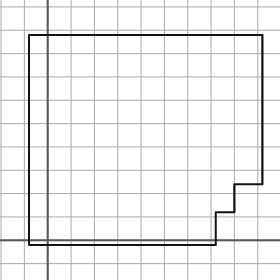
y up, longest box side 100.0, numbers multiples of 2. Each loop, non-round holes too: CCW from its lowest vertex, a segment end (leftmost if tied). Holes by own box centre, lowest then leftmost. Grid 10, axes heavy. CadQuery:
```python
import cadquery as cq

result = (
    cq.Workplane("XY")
    .moveTo(-8.0, -2.0)
    .lineTo(72.0, -2.0)
    .lineTo(72.0, 12.0)
    .lineTo(80.0, 12.0)
    .lineTo(80.0, 24.0)
    .lineTo(92.0, 24.0)
    .lineTo(92.0, 88.0)
    .lineTo(-8.0, 88.0)
    .close()
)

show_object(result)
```